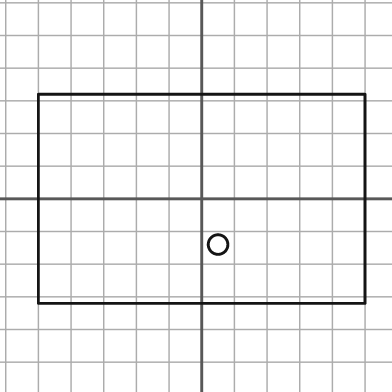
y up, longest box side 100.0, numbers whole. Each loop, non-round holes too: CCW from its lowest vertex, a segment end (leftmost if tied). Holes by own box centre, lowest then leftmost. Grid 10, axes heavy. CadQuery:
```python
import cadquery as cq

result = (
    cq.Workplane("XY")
    .moveTo(-50.0, -32.0)
    .lineTo(50.0, -32.0)
    .lineTo(50.0, 32.0)
    .lineTo(-50.0, 32.0)
    .close()
    .moveTo(5.0, -14.0)
    .circle(3.0)
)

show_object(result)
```